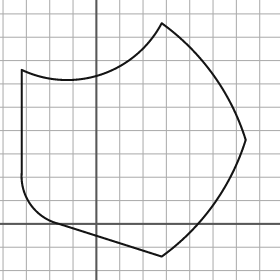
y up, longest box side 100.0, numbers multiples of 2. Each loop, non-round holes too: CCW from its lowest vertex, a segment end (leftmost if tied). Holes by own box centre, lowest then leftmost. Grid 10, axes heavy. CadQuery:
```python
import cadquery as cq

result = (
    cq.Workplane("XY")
    .moveTo(28.0, -14.0)
    .threePointArc((50.0, 8.0), (64.0, 36.0))
    .threePointArc((50.0, 64.0), (28.0, 86.0))
    .threePointArc((2.0, 64.0), (-32.0, 66.0))
    .lineTo(-32.0, 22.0)
    .threePointArc((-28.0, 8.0), (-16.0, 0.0))
    .close()
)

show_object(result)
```